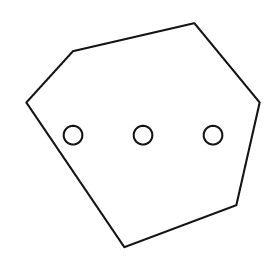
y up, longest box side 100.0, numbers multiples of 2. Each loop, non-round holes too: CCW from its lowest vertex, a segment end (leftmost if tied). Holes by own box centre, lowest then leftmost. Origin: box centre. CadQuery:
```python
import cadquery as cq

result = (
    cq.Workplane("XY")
    .moveTo(-8.0, -48.0)
    .lineTo(40.0, -30.0)
    .lineTo(50.0, 14.0)
    .lineTo(22.0, 48.0)
    .lineTo(-30.0, 36.0)
    .lineTo(-50.0, 14.0)
    .close()
    .moveTo(-30.0, 0.0)
    .circle(4.0)
    .moveTo(0.0, 0.0)
    .circle(4.0)
    .moveTo(30.0, 0.0)
    .circle(4.0)
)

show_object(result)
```